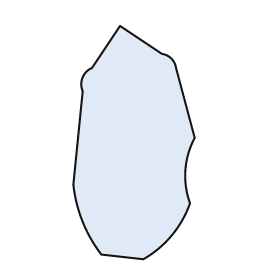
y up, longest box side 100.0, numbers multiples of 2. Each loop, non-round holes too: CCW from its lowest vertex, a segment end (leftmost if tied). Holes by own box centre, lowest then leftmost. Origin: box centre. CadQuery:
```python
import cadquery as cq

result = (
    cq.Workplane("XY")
    .moveTo(4.0, -50.0)
    .threePointArc((16.0, -40.0), (24.0, -26.0))
    .threePointArc((22.0, -12.0), (26.0, 2.0))
    .lineTo(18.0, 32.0)
    .threePointArc((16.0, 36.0), (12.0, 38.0))
    .lineTo(-6.0, 50.0)
    .lineTo(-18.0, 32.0)
    .threePointArc((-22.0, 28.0), (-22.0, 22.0))
    .lineTo(-26.0, -18.0)
    .threePointArc((-22.0, -34.0), (-14.0, -48.0))
    .close()
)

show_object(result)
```